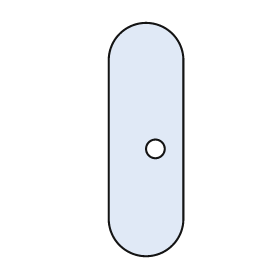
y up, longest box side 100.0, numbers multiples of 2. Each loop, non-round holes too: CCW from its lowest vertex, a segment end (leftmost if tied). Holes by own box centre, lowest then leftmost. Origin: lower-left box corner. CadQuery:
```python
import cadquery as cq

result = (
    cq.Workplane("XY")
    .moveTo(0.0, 16.0)
    .threePointArc((16.0, 0.0), (32.0, 16.0))
    .lineTo(32.0, 84.0)
    .threePointArc((16.0, 100.0), (0.0, 84.0))
    .close()
    .moveTo(20.0, 46.0)
    .circle(4.0)
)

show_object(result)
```